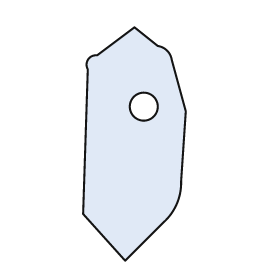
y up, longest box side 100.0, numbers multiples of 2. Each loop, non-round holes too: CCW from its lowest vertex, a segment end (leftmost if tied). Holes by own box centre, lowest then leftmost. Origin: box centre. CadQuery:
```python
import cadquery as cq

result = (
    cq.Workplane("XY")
    .moveTo(-4.0, -50.0)
    .lineTo(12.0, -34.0)
    .threePointArc((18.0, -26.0), (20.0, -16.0))
    .lineTo(22.0, 14.0)
    .lineTo(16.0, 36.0)
    .threePointArc((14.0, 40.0), (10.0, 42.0))
    .lineTo(0.0, 50.0)
    .lineTo(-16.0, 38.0)
    .threePointArc((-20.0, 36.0), (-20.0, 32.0))
    .lineTo(-22.0, -30.0)
    .close()
    .moveTo(4.0, 16.0)
    .circle(6.0)
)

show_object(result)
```